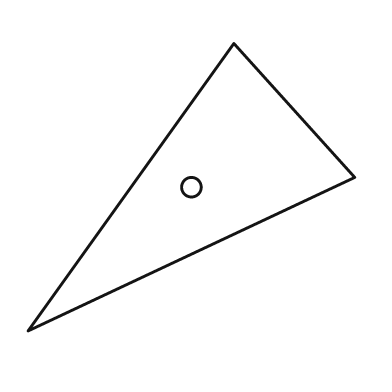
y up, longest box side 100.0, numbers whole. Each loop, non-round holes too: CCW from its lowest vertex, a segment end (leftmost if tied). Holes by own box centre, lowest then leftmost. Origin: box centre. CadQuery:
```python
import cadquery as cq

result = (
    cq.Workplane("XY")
    .moveTo(-50.0, -44.0)
    .lineTo(50.0, 3.0)
    .lineTo(13.0, 44.0)
    .close()
    .moveTo(0.0, 0.0)
    .circle(3.0)
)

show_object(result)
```